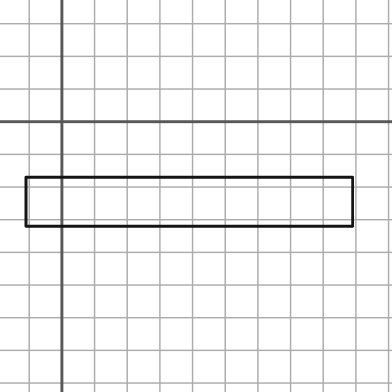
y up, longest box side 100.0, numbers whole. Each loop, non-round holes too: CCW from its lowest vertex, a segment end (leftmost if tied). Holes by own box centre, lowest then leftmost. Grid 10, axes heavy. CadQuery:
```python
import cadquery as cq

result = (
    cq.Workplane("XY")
    .moveTo(-11.0, -32.0)
    .lineTo(89.0, -32.0)
    .lineTo(89.0, -17.0)
    .lineTo(-11.0, -17.0)
    .close()
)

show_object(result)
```